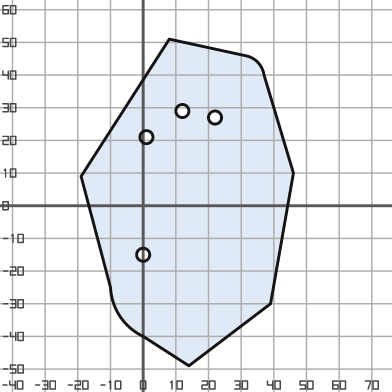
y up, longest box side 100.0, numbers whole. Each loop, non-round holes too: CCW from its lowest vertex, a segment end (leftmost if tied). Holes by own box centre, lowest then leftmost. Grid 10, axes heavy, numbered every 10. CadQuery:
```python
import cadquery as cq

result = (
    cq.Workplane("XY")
    .moveTo(14.0, -49.0)
    .lineTo(39.0, -30.0)
    .lineTo(46.0, 10.0)
    .lineTo(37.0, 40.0)
    .threePointArc((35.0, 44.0), (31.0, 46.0))
    .lineTo(8.0, 51.0)
    .lineTo(-19.0, 9.0)
    .lineTo(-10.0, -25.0)
    .threePointArc((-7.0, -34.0), (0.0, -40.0))
    .close()
    .moveTo(0.0, -15.0)
    .circle(2.0)
    .moveTo(1.0, 21.0)
    .circle(2.0)
    .moveTo(22.0, 27.0)
    .circle(2.0)
    .moveTo(12.0, 29.0)
    .circle(2.0)
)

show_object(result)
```